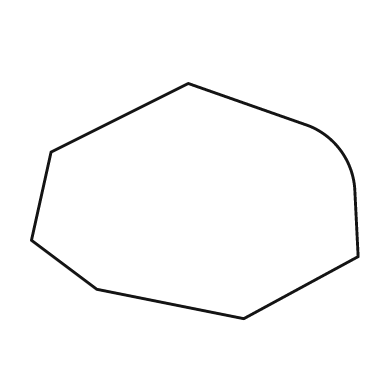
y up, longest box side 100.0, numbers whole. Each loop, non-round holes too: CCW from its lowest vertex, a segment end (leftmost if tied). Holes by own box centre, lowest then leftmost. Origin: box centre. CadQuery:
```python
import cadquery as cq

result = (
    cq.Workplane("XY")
    .moveTo(15.0, -36.0)
    .lineTo(50.0, -17.0)
    .lineTo(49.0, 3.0)
    .threePointArc((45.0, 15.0), (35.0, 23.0))
    .lineTo(-2.0, 36.0)
    .lineTo(-44.0, 15.0)
    .lineTo(-50.0, -12.0)
    .lineTo(-30.0, -27.0)
    .close()
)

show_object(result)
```